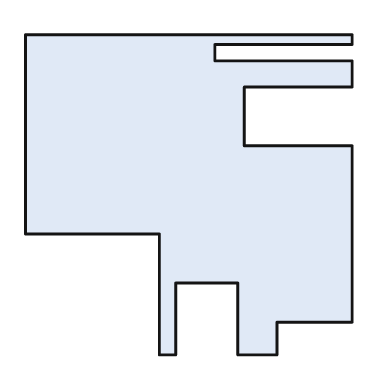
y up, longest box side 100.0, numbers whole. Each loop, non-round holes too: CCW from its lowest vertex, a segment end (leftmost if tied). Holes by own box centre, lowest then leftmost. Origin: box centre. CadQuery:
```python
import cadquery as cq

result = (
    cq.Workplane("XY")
    .moveTo(-9.0, -49.0)
    .lineTo(-4.0, -49.0)
    .lineTo(-4.0, -27.0)
    .lineTo(15.0, -27.0)
    .lineTo(15.0, -49.0)
    .lineTo(27.0, -49.0)
    .lineTo(27.0, -39.0)
    .lineTo(50.0, -39.0)
    .lineTo(50.0, 15.0)
    .lineTo(17.0, 15.0)
    .lineTo(17.0, 33.0)
    .lineTo(50.0, 33.0)
    .lineTo(50.0, 41.0)
    .lineTo(8.0, 41.0)
    .lineTo(8.0, 46.0)
    .lineTo(50.0, 46.0)
    .lineTo(50.0, 49.0)
    .lineTo(-50.0, 49.0)
    .lineTo(-50.0, -12.0)
    .lineTo(-9.0, -12.0)
    .close()
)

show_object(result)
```